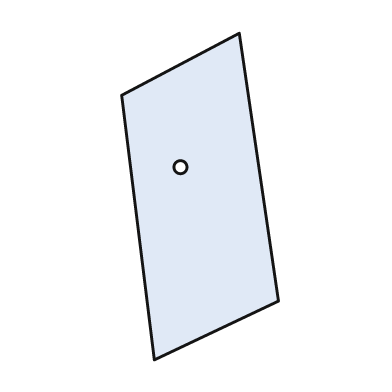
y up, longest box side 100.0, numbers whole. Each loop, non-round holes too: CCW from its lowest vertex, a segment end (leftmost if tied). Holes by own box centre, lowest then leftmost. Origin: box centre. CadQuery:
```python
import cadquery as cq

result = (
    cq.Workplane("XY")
    .moveTo(-14.0, -50.0)
    .lineTo(24.0, -32.0)
    .lineTo(12.0, 50.0)
    .lineTo(-24.0, 31.0)
    .close()
    .moveTo(-6.0, 9.0)
    .circle(2.0)
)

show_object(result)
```